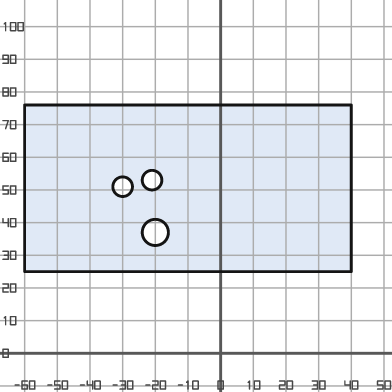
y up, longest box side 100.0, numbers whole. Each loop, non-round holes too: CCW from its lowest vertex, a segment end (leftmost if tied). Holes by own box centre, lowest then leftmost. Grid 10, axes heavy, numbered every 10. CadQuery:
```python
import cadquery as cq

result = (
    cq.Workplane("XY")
    .moveTo(-60.0, 25.0)
    .lineTo(40.0, 25.0)
    .lineTo(40.0, 76.0)
    .lineTo(-60.0, 76.0)
    .close()
    .moveTo(-20.0, 37.0)
    .circle(4.0)
    .moveTo(-30.0, 51.0)
    .circle(3.0)
    .moveTo(-21.0, 53.0)
    .circle(3.0)
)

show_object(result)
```